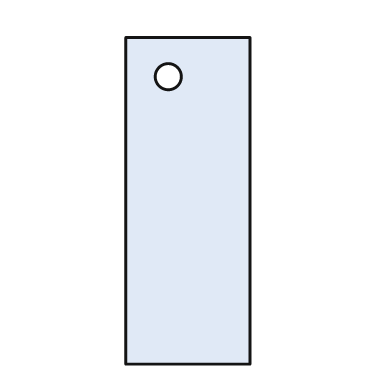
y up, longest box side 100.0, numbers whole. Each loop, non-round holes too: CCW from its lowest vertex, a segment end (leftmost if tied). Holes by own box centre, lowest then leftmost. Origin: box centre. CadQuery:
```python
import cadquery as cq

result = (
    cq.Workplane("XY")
    .moveTo(-19.0, -50.0)
    .lineTo(19.0, -50.0)
    .lineTo(19.0, 50.0)
    .lineTo(-19.0, 50.0)
    .close()
    .moveTo(-6.0, 38.0)
    .circle(4.0)
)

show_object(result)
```